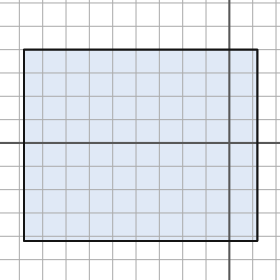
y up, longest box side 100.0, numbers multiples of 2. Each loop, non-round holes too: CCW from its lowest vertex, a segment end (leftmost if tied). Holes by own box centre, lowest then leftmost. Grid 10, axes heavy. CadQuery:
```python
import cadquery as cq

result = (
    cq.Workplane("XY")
    .moveTo(-88.0, -42.0)
    .lineTo(12.0, -42.0)
    .lineTo(12.0, 40.0)
    .lineTo(-88.0, 40.0)
    .close()
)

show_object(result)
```